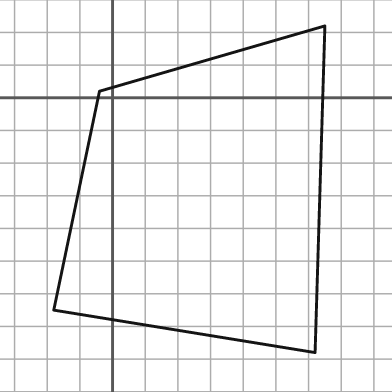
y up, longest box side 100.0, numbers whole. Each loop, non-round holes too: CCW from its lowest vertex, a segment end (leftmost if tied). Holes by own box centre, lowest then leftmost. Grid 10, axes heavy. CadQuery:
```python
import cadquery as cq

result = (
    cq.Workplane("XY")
    .moveTo(62.0, -78.0)
    .lineTo(65.0, 22.0)
    .lineTo(-4.0, 2.0)
    .lineTo(-18.0, -65.0)
    .close()
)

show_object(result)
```